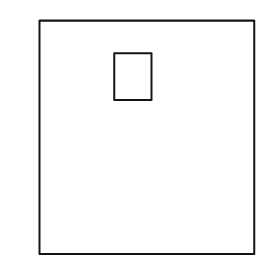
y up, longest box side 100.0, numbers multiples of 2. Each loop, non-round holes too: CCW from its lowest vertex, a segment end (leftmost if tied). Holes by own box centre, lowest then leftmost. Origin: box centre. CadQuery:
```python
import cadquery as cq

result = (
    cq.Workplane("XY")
    .moveTo(-46.0, -50.0)
    .lineTo(46.0, -50.0)
    .lineTo(46.0, 50.0)
    .lineTo(-46.0, 50.0)
    .close()
    .moveTo(-14.0, 16.0)
    .lineTo(2.0, 16.0)
    .lineTo(2.0, 36.0)
    .lineTo(-14.0, 36.0)
    .close()
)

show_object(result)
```